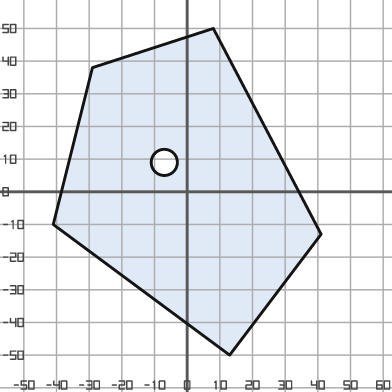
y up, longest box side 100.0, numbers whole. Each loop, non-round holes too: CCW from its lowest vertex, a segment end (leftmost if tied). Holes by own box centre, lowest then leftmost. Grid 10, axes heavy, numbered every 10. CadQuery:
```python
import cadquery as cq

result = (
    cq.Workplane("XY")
    .moveTo(13.0, -50.0)
    .lineTo(41.0, -13.0)
    .lineTo(8.0, 50.0)
    .lineTo(-29.0, 38.0)
    .lineTo(-41.0, -10.0)
    .close()
    .moveTo(-7.0, 9.0)
    .circle(4.0)
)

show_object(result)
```